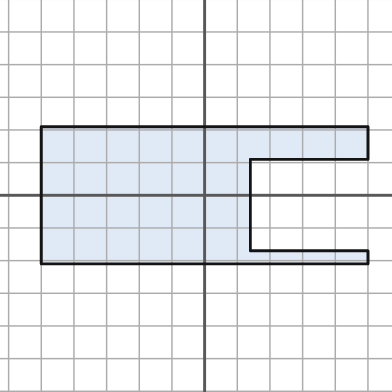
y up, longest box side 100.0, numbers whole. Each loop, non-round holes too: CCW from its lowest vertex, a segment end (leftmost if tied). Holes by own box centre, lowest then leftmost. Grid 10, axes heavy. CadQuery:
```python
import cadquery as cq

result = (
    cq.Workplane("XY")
    .moveTo(-50.0, -21.0)
    .lineTo(50.0, -21.0)
    .lineTo(50.0, -17.0)
    .lineTo(14.0, -17.0)
    .lineTo(14.0, 11.0)
    .lineTo(50.0, 11.0)
    .lineTo(50.0, 21.0)
    .lineTo(-50.0, 21.0)
    .close()
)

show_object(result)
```